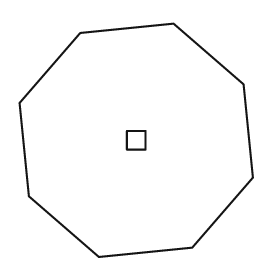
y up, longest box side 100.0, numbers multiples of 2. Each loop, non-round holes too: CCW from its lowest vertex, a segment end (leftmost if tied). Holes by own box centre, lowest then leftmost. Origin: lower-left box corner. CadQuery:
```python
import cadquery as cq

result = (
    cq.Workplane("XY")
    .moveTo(34.0, 0.0)
    .lineTo(74.0, 4.0)
    .lineTo(100.0, 34.0)
    .lineTo(96.0, 74.0)
    .lineTo(66.0, 100.0)
    .lineTo(26.0, 96.0)
    .lineTo(0.0, 66.0)
    .lineTo(4.0, 26.0)
    .close()
    .moveTo(46.0, 46.0)
    .lineTo(54.0, 46.0)
    .lineTo(54.0, 54.0)
    .lineTo(46.0, 54.0)
    .close()
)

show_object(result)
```